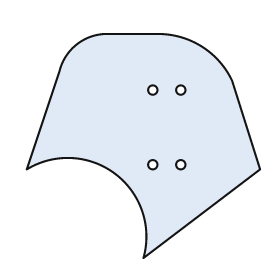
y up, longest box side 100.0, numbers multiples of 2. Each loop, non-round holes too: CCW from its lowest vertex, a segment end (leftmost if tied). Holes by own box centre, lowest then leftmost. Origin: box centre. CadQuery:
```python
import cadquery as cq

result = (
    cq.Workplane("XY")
    .moveTo(0.0, -48.0)
    .lineTo(50.0, -10.0)
    .lineTo(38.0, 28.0)
    .threePointArc((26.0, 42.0), (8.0, 48.0))
    .lineTo(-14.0, 48.0)
    .threePointArc((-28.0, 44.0), (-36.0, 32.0))
    .lineTo(-50.0, -10.0)
    .threePointArc((-12.0, -12.0), (0.0, -48.0))
    .close()
    .moveTo(4.0, -8.0)
    .circle(2.0)
    .moveTo(16.0, -8.0)
    .circle(2.0)
    .moveTo(4.0, 24.0)
    .circle(2.0)
    .moveTo(16.0, 24.0)
    .circle(2.0)
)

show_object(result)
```